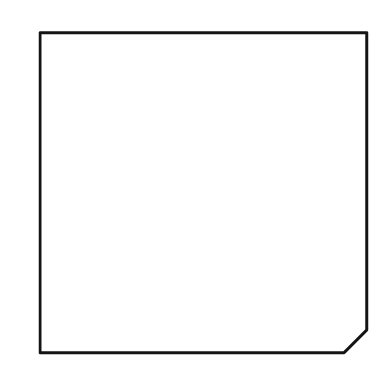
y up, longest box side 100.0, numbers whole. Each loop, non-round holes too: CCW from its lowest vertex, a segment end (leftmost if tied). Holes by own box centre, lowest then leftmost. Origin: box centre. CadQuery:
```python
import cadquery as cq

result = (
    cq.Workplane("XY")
    .moveTo(-50.0, -49.0)
    .lineTo(43.0, -49.0)
    .lineTo(50.0, -42.0)
    .lineTo(50.0, 49.0)
    .lineTo(-50.0, 49.0)
    .close()
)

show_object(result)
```